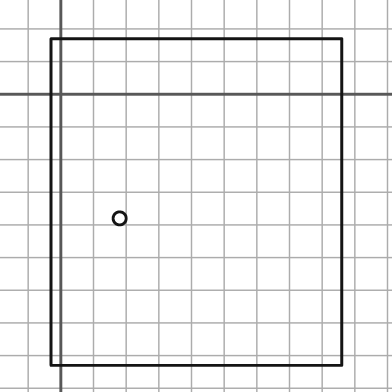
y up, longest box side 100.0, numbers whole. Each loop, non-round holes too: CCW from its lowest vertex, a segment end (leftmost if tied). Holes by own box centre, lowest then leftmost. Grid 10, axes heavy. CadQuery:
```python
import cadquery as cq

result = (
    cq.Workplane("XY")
    .moveTo(-3.0, -83.0)
    .lineTo(86.0, -83.0)
    .lineTo(86.0, 17.0)
    .lineTo(-3.0, 17.0)
    .close()
    .moveTo(18.0, -38.0)
    .circle(2.0)
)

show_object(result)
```